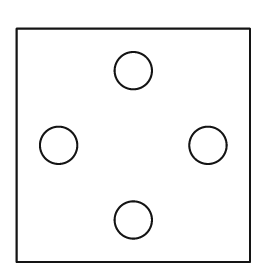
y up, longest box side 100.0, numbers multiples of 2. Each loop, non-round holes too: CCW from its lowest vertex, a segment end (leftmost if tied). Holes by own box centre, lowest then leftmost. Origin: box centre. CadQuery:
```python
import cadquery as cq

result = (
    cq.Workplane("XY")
    .moveTo(-50.0, -50.0)
    .lineTo(50.0, -50.0)
    .lineTo(50.0, 50.0)
    .lineTo(-50.0, 50.0)
    .close()
    .moveTo(0.0, -32.0)
    .circle(8.0)
    .moveTo(-32.0, 0.0)
    .circle(8.0)
    .moveTo(32.0, 0.0)
    .circle(8.0)
    .moveTo(0.0, 32.0)
    .circle(8.0)
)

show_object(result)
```